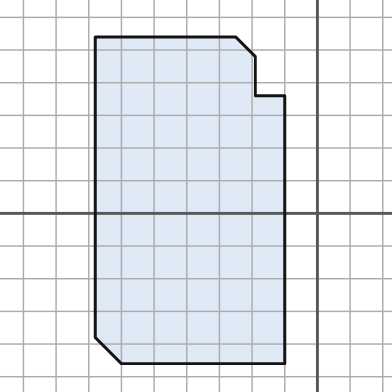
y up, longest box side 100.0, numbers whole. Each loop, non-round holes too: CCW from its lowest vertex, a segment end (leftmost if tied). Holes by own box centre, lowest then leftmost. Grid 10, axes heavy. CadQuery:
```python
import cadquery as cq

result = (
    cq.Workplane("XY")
    .moveTo(-60.0, -46.0)
    .lineTo(-10.0, -46.0)
    .lineTo(-10.0, 36.0)
    .lineTo(-19.0, 36.0)
    .lineTo(-19.0, 48.0)
    .lineTo(-25.0, 54.0)
    .lineTo(-68.0, 54.0)
    .lineTo(-68.0, -38.0)
    .close()
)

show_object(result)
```